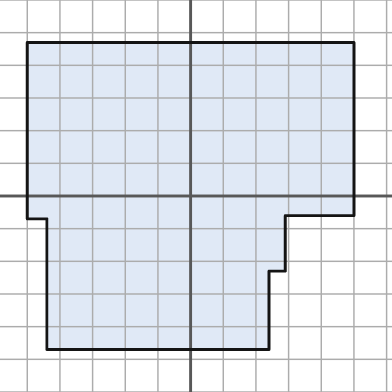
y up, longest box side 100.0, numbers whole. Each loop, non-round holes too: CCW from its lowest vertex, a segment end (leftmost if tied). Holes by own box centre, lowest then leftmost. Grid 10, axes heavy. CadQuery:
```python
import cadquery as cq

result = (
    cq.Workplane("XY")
    .moveTo(-44.0, -47.0)
    .lineTo(24.0, -47.0)
    .lineTo(24.0, -23.0)
    .lineTo(29.0, -23.0)
    .lineTo(29.0, -6.0)
    .lineTo(50.0, -6.0)
    .lineTo(50.0, 47.0)
    .lineTo(-50.0, 47.0)
    .lineTo(-50.0, -7.0)
    .lineTo(-44.0, -7.0)
    .close()
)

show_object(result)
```